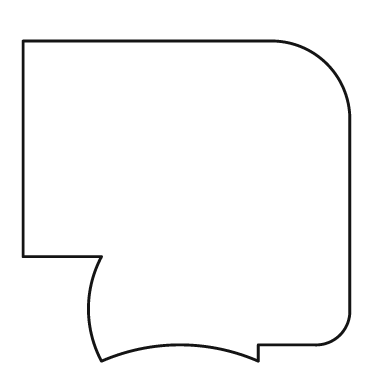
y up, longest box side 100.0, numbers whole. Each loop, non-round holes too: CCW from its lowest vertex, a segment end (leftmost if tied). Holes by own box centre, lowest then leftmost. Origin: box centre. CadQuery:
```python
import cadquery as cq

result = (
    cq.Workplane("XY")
    .moveTo(-26.0, -49.0)
    .threePointArc((-2.0, -44.0), (22.0, -49.0))
    .lineTo(22.0, -44.0)
    .lineTo(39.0, -44.0)
    .threePointArc((47.0, -41.0), (50.0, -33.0))
    .lineTo(50.0, 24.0)
    .threePointArc((43.0, 42.0), (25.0, 49.0))
    .lineTo(-50.0, 49.0)
    .lineTo(-50.0, -17.0)
    .lineTo(-26.0, -17.0)
    .threePointArc((-30.0, -33.0), (-26.0, -49.0))
    .close()
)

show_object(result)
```